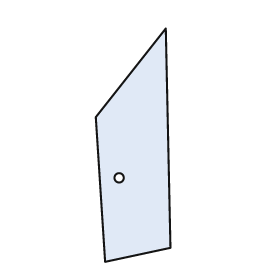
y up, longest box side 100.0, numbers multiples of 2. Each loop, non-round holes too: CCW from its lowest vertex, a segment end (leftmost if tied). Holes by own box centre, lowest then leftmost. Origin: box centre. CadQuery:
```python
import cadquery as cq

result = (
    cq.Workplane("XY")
    .moveTo(-12.0, -50.0)
    .lineTo(16.0, -44.0)
    .lineTo(14.0, 50.0)
    .lineTo(-16.0, 12.0)
    .close()
    .moveTo(-6.0, -14.0)
    .circle(2.0)
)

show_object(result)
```